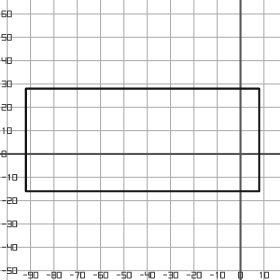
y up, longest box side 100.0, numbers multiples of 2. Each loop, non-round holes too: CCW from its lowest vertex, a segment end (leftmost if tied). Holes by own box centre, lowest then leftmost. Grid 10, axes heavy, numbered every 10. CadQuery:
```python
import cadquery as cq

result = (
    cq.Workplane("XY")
    .moveTo(-92.0, -16.0)
    .lineTo(8.0, -16.0)
    .lineTo(8.0, 28.0)
    .lineTo(-92.0, 28.0)
    .close()
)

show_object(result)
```